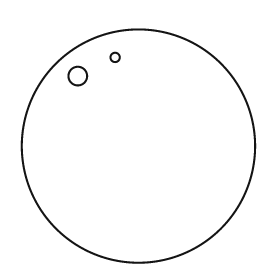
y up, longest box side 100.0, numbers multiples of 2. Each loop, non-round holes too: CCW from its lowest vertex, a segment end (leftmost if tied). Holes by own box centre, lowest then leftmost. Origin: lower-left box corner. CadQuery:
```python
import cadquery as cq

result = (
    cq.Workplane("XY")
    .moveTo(50.0, 50.0)
    .circle(50.0)
    .moveTo(24.0, 80.0)
    .circle(4.0)
    .moveTo(40.0, 88.0)
    .circle(2.0)
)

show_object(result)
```